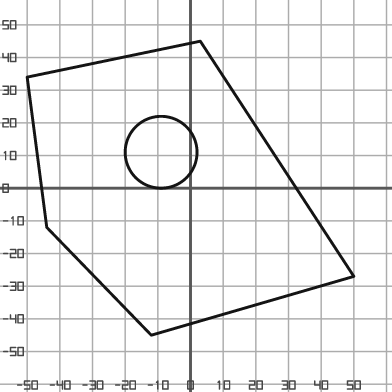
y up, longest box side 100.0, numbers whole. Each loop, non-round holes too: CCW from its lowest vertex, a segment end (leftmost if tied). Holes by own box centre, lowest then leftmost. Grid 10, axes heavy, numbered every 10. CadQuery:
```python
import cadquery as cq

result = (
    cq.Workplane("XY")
    .moveTo(-12.0, -45.0)
    .lineTo(50.0, -27.0)
    .lineTo(3.0, 45.0)
    .lineTo(-50.0, 34.0)
    .lineTo(-44.0, -12.0)
    .close()
    .moveTo(-9.0, 11.0)
    .circle(11.0)
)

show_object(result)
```